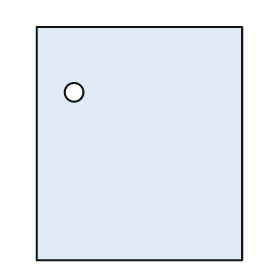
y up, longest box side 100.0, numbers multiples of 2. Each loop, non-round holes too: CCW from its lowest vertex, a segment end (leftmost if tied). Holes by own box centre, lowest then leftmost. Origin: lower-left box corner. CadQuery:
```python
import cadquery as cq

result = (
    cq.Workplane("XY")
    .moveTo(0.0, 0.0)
    .lineTo(88.0, 0.0)
    .lineTo(88.0, 100.0)
    .lineTo(0.0, 100.0)
    .close()
    .moveTo(16.0, 72.0)
    .circle(4.0)
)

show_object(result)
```